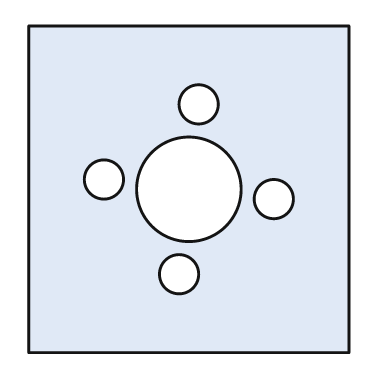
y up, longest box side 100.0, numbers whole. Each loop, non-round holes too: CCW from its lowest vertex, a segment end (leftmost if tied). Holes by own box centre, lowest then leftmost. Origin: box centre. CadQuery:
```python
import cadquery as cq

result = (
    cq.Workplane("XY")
    .moveTo(-49.0, -50.0)
    .lineTo(49.0, -50.0)
    .lineTo(49.0, 50.0)
    .lineTo(-49.0, 50.0)
    .close()
    .moveTo(-3.0, -26.0)
    .circle(6.0)
    .moveTo(26.0, -3.0)
    .circle(6.0)
    .moveTo(0.0, 0.0)
    .circle(16.0)
    .moveTo(-26.0, 3.0)
    .circle(6.0)
    .moveTo(3.0, 26.0)
    .circle(6.0)
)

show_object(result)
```